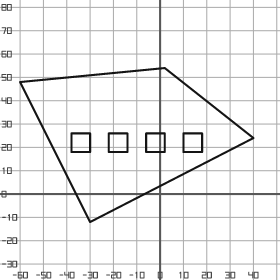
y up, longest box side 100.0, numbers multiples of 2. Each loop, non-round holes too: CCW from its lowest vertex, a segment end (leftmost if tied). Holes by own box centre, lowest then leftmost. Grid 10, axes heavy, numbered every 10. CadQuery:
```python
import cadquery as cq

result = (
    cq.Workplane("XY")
    .moveTo(-30.0, -12.0)
    .lineTo(40.0, 24.0)
    .lineTo(2.0, 54.0)
    .lineTo(-60.0, 48.0)
    .close()
    .moveTo(-38.0, 18.0)
    .lineTo(-30.0, 18.0)
    .lineTo(-30.0, 26.0)
    .lineTo(-38.0, 26.0)
    .close()
    .moveTo(-22.0, 18.0)
    .lineTo(-14.0, 18.0)
    .lineTo(-14.0, 26.0)
    .lineTo(-22.0, 26.0)
    .close()
    .moveTo(-6.0, 18.0)
    .lineTo(2.0, 18.0)
    .lineTo(2.0, 26.0)
    .lineTo(-6.0, 26.0)
    .close()
    .moveTo(10.0, 18.0)
    .lineTo(18.0, 18.0)
    .lineTo(18.0, 26.0)
    .lineTo(10.0, 26.0)
    .close()
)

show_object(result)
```